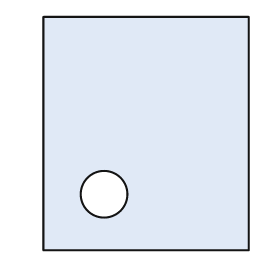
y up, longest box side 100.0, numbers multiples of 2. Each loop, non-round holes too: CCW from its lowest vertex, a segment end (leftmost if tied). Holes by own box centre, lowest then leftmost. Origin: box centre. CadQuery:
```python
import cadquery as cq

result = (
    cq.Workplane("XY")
    .moveTo(-44.0, -50.0)
    .lineTo(44.0, -50.0)
    .lineTo(44.0, 50.0)
    .lineTo(-44.0, 50.0)
    .close()
    .moveTo(-18.0, -26.0)
    .circle(10.0)
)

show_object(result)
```